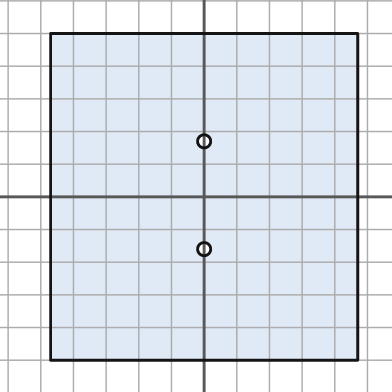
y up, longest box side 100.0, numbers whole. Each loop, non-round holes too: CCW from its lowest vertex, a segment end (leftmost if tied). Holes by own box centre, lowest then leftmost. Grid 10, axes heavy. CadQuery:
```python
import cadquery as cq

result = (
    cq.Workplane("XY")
    .moveTo(-47.0, -50.0)
    .lineTo(47.0, -50.0)
    .lineTo(47.0, 50.0)
    .lineTo(-47.0, 50.0)
    .close()
    .moveTo(0.0, -16.0)
    .circle(2.0)
    .moveTo(0.0, 17.0)
    .circle(2.0)
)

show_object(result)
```